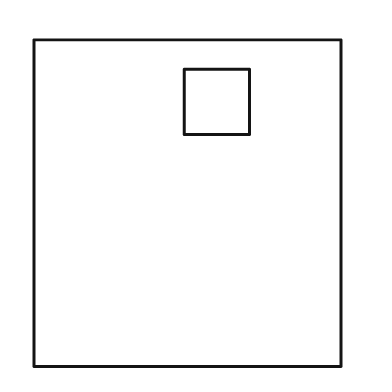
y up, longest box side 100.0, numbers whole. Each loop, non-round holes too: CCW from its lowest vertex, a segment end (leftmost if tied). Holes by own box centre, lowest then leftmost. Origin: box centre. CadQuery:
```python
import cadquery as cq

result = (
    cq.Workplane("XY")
    .moveTo(-47.0, -50.0)
    .lineTo(47.0, -50.0)
    .lineTo(47.0, 50.0)
    .lineTo(-47.0, 50.0)
    .close()
    .moveTo(-1.0, 21.0)
    .lineTo(19.0, 21.0)
    .lineTo(19.0, 41.0)
    .lineTo(-1.0, 41.0)
    .close()
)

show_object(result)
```